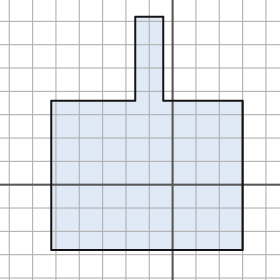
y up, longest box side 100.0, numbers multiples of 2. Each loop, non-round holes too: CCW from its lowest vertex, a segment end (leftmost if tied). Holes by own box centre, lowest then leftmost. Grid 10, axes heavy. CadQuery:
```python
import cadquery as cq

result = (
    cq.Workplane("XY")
    .moveTo(-52.0, -28.0)
    .lineTo(30.0, -28.0)
    .lineTo(30.0, 36.0)
    .lineTo(-4.0, 36.0)
    .lineTo(-4.0, 72.0)
    .lineTo(-16.0, 72.0)
    .lineTo(-16.0, 36.0)
    .lineTo(-52.0, 36.0)
    .close()
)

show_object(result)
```